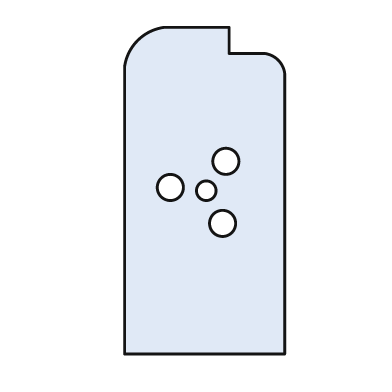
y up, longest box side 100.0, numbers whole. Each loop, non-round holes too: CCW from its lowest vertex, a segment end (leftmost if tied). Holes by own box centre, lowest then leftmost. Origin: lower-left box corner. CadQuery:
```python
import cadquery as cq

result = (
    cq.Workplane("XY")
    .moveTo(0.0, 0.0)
    .lineTo(49.0, 0.0)
    .lineTo(49.0, 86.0)
    .threePointArc((47.0, 90.0), (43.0, 92.0))
    .lineTo(32.0, 92.0)
    .lineTo(32.0, 100.0)
    .lineTo(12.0, 100.0)
    .threePointArc((4.0, 96.0), (0.0, 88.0))
    .close()
    .moveTo(30.0, 40.0)
    .circle(4.0)
    .moveTo(25.0, 50.0)
    .circle(3.0)
    .moveTo(14.0, 51.0)
    .circle(4.0)
    .moveTo(31.0, 59.0)
    .circle(4.0)
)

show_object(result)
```